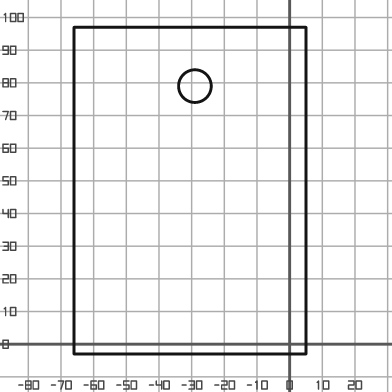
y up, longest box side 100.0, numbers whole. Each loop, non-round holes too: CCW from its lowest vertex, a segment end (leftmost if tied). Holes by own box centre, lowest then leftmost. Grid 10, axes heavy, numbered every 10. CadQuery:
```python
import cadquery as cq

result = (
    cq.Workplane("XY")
    .moveTo(-66.0, -3.0)
    .lineTo(5.0, -3.0)
    .lineTo(5.0, 97.0)
    .lineTo(-66.0, 97.0)
    .close()
    .moveTo(-29.0, 79.0)
    .circle(5.0)
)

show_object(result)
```